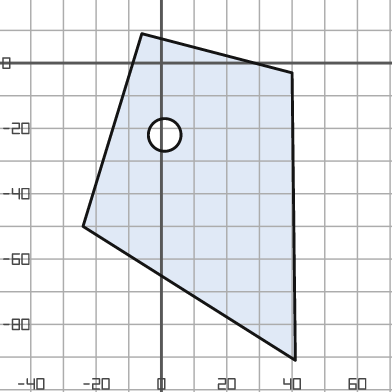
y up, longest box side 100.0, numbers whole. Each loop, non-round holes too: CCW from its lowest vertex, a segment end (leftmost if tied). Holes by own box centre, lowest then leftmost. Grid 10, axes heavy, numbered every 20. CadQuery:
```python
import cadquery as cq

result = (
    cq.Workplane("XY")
    .moveTo(41.0, -91.0)
    .lineTo(40.0, -3.0)
    .lineTo(-6.0, 9.0)
    .lineTo(-24.0, -50.0)
    .close()
    .moveTo(1.0, -22.0)
    .circle(5.0)
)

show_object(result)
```